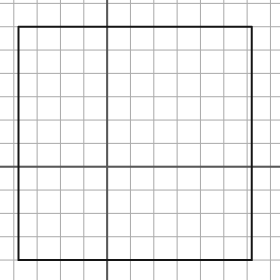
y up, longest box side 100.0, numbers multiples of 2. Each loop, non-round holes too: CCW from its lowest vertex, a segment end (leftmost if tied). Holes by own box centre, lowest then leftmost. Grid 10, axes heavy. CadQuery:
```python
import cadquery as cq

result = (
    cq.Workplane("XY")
    .moveTo(-38.0, -40.0)
    .lineTo(62.0, -40.0)
    .lineTo(62.0, 60.0)
    .lineTo(-38.0, 60.0)
    .close()
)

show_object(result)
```